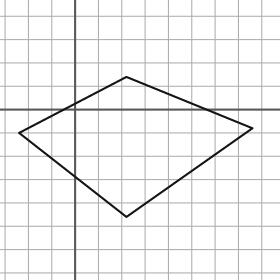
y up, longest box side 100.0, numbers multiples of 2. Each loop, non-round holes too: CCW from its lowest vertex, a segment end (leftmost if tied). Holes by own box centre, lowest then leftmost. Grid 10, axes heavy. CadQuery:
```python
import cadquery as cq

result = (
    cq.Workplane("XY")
    .moveTo(22.0, -46.0)
    .lineTo(76.0, -8.0)
    .lineTo(22.0, 14.0)
    .lineTo(-24.0, -10.0)
    .close()
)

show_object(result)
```